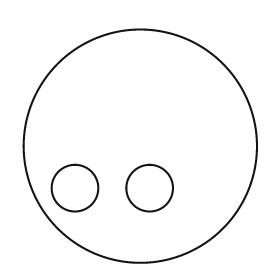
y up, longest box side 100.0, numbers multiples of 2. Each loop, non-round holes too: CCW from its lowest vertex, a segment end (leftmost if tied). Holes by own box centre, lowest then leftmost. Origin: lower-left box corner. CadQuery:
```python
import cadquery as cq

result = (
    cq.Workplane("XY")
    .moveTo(50.0, 50.0)
    .circle(50.0)
    .moveTo(22.0, 32.0)
    .circle(10.0)
    .moveTo(54.0, 32.0)
    .circle(10.0)
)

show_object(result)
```